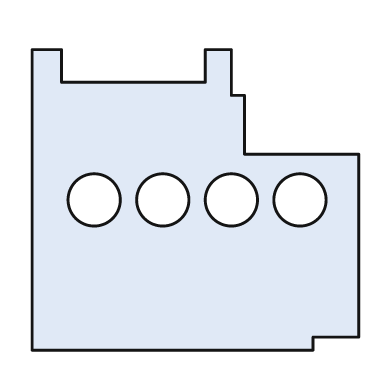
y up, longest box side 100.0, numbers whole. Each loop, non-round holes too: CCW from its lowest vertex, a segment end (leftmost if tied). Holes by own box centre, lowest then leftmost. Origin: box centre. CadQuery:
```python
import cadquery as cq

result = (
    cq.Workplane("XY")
    .moveTo(-50.0, -46.0)
    .lineTo(36.0, -46.0)
    .lineTo(36.0, -42.0)
    .lineTo(50.0, -42.0)
    .lineTo(50.0, 14.0)
    .lineTo(15.0, 14.0)
    .lineTo(15.0, 32.0)
    .lineTo(11.0, 32.0)
    .lineTo(11.0, 46.0)
    .lineTo(3.0, 46.0)
    .lineTo(3.0, 36.0)
    .lineTo(-41.0, 36.0)
    .lineTo(-41.0, 46.0)
    .lineTo(-50.0, 46.0)
    .close()
    .moveTo(-31.0, 0.0)
    .circle(8.0)
    .moveTo(-10.0, 0.0)
    .circle(8.0)
    .moveTo(11.0, 0.0)
    .circle(8.0)
    .moveTo(32.0, 0.0)
    .circle(8.0)
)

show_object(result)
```